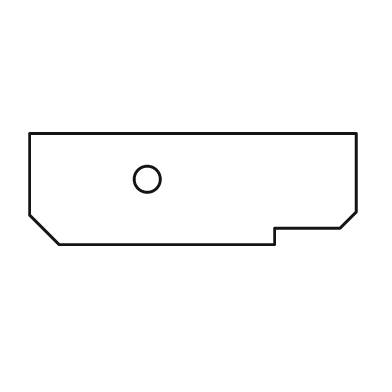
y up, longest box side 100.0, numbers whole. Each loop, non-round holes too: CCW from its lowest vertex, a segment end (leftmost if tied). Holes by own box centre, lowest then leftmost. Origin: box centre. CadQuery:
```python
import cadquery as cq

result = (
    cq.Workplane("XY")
    .moveTo(-41.0, -17.0)
    .lineTo(25.0, -17.0)
    .lineTo(25.0, -12.0)
    .lineTo(45.0, -12.0)
    .lineTo(50.0, -7.0)
    .lineTo(50.0, 17.0)
    .lineTo(-50.0, 17.0)
    .lineTo(-50.0, -8.0)
    .close()
    .moveTo(-14.0, 3.0)
    .circle(4.0)
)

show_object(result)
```